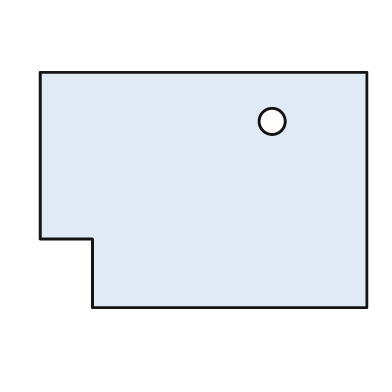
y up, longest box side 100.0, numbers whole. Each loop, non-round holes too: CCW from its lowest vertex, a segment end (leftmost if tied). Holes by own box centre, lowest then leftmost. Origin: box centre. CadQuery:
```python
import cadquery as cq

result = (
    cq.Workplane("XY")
    .moveTo(-34.0, -36.0)
    .lineTo(50.0, -36.0)
    .lineTo(50.0, 36.0)
    .lineTo(-50.0, 36.0)
    .lineTo(-50.0, -15.0)
    .lineTo(-34.0, -15.0)
    .close()
    .moveTo(21.0, 21.0)
    .circle(4.0)
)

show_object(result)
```